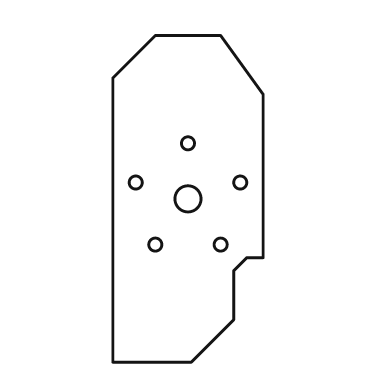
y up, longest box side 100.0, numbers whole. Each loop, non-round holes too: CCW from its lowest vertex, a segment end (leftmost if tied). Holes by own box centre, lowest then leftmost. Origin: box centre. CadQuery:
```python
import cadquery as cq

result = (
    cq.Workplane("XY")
    .moveTo(-23.0, -50.0)
    .lineTo(1.0, -50.0)
    .lineTo(14.0, -37.0)
    .lineTo(14.0, -22.0)
    .lineTo(18.0, -18.0)
    .lineTo(23.0, -18.0)
    .lineTo(23.0, 32.0)
    .lineTo(10.0, 50.0)
    .lineTo(-10.0, 50.0)
    .lineTo(-23.0, 37.0)
    .close()
    .moveTo(-10.0, -14.0)
    .circle(2.0)
    .moveTo(10.0, -14.0)
    .circle(2.0)
    .moveTo(0.0, 0.0)
    .circle(4.0)
    .moveTo(-16.0, 5.0)
    .circle(2.0)
    .moveTo(16.0, 5.0)
    .circle(2.0)
    .moveTo(0.0, 17.0)
    .circle(2.0)
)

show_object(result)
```